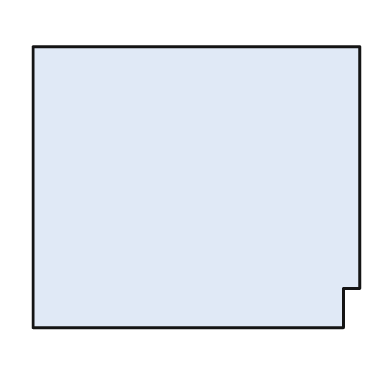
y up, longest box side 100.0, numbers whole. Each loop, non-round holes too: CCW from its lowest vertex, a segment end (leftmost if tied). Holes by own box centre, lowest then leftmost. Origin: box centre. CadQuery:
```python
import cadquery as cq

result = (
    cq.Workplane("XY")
    .moveTo(-50.0, -43.0)
    .lineTo(45.0, -43.0)
    .lineTo(45.0, -31.0)
    .lineTo(50.0, -31.0)
    .lineTo(50.0, 43.0)
    .lineTo(-50.0, 43.0)
    .close()
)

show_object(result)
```